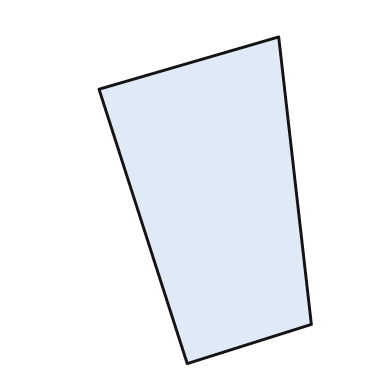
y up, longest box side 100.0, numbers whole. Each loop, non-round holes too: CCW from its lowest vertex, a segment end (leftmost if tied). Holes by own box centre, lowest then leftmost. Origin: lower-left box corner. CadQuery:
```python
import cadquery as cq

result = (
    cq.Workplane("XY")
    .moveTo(27.0, 0.0)
    .lineTo(65.0, 12.0)
    .lineTo(55.0, 100.0)
    .lineTo(0.0, 84.0)
    .close()
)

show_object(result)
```